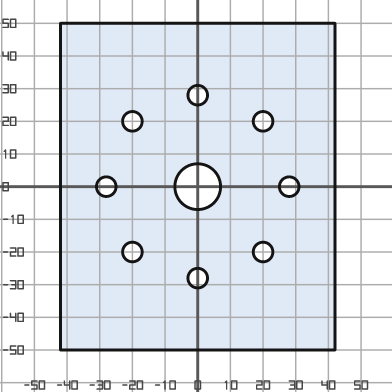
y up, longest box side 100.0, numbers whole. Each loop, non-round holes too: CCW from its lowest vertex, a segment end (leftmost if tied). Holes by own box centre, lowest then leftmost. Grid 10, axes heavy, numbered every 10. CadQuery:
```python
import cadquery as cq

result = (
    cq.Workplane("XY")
    .moveTo(-42.0, -50.0)
    .lineTo(42.0, -50.0)
    .lineTo(42.0, 50.0)
    .lineTo(-42.0, 50.0)
    .close()
    .moveTo(0.0, -28.0)
    .circle(3.0)
    .moveTo(-20.0, -20.0)
    .circle(3.0)
    .moveTo(20.0, -20.0)
    .circle(3.0)
    .moveTo(-28.0, 0.0)
    .circle(3.0)
    .moveTo(0.0, 0.0)
    .circle(7.0)
    .moveTo(28.0, 0.0)
    .circle(3.0)
    .moveTo(-20.0, 20.0)
    .circle(3.0)
    .moveTo(20.0, 20.0)
    .circle(3.0)
    .moveTo(0.0, 28.0)
    .circle(3.0)
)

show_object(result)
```